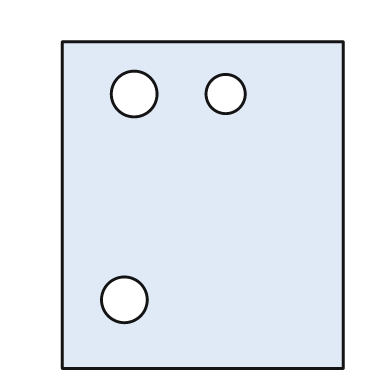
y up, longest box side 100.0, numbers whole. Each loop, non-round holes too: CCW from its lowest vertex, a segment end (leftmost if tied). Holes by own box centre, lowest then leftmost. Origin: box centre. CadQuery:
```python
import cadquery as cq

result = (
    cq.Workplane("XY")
    .moveTo(-43.0, -50.0)
    .lineTo(43.0, -50.0)
    .lineTo(43.0, 50.0)
    .lineTo(-43.0, 50.0)
    .close()
    .moveTo(-24.0, -29.0)
    .circle(7.0)
    .moveTo(-21.0, 34.0)
    .circle(7.0)
    .moveTo(7.0, 34.0)
    .circle(6.0)
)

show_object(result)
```